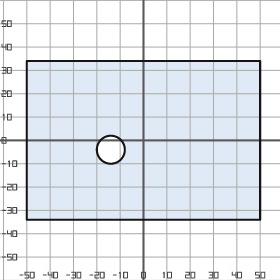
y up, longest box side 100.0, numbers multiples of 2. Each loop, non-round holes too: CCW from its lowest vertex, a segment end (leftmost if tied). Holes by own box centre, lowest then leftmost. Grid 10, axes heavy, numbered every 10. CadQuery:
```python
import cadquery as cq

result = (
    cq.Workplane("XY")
    .moveTo(-50.0, -34.0)
    .lineTo(50.0, -34.0)
    .lineTo(50.0, 34.0)
    .lineTo(-50.0, 34.0)
    .close()
    .moveTo(-14.0, -4.0)
    .circle(6.0)
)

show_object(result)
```